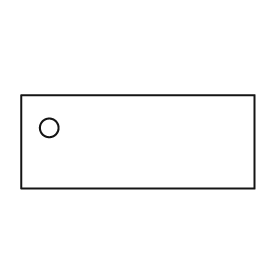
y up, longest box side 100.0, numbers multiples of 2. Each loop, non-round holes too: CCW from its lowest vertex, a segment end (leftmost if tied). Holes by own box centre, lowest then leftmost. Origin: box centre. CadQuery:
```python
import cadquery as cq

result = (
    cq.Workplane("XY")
    .moveTo(-50.0, -20.0)
    .lineTo(50.0, -20.0)
    .lineTo(50.0, 20.0)
    .lineTo(-50.0, 20.0)
    .close()
    .moveTo(-38.0, 6.0)
    .circle(4.0)
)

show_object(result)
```